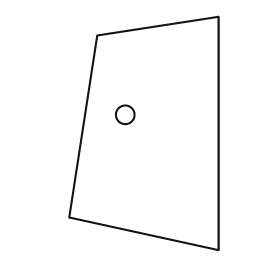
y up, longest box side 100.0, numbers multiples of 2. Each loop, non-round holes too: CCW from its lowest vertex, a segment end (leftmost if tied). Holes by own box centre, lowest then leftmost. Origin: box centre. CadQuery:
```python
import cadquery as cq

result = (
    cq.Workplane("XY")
    .moveTo(32.0, -50.0)
    .lineTo(32.0, 50.0)
    .lineTo(-20.0, 42.0)
    .lineTo(-32.0, -36.0)
    .close()
    .moveTo(-8.0, 8.0)
    .circle(4.0)
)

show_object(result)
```